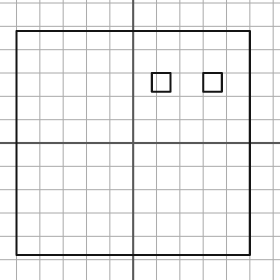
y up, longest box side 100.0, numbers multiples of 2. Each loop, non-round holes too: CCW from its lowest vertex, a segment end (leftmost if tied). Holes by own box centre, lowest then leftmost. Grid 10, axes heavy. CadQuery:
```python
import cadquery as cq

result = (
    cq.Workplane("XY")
    .moveTo(-50.0, -48.0)
    .lineTo(50.0, -48.0)
    .lineTo(50.0, 48.0)
    .lineTo(-50.0, 48.0)
    .close()
    .moveTo(8.0, 22.0)
    .lineTo(16.0, 22.0)
    .lineTo(16.0, 30.0)
    .lineTo(8.0, 30.0)
    .close()
    .moveTo(30.0, 22.0)
    .lineTo(38.0, 22.0)
    .lineTo(38.0, 30.0)
    .lineTo(30.0, 30.0)
    .close()
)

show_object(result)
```